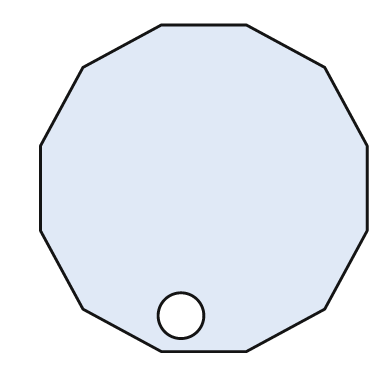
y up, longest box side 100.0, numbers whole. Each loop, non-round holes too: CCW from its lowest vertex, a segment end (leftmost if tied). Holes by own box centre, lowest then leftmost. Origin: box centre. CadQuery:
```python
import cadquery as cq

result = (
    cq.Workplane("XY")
    .moveTo(-13.0, -50.0)
    .lineTo(13.0, -50.0)
    .lineTo(37.0, -37.0)
    .lineTo(50.0, -13.0)
    .lineTo(50.0, 13.0)
    .lineTo(37.0, 37.0)
    .lineTo(13.0, 50.0)
    .lineTo(-13.0, 50.0)
    .lineTo(-37.0, 37.0)
    .lineTo(-50.0, 13.0)
    .lineTo(-50.0, -13.0)
    .lineTo(-37.0, -37.0)
    .close()
    .moveTo(-7.0, -39.0)
    .circle(7.0)
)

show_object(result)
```